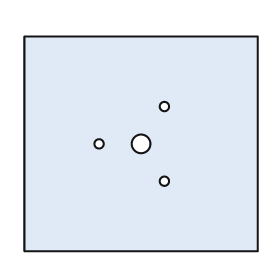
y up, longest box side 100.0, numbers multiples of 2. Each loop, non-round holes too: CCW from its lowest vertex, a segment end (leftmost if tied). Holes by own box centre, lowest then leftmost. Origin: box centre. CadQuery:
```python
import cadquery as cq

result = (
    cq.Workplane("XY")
    .moveTo(-50.0, -46.0)
    .lineTo(50.0, -46.0)
    .lineTo(50.0, 46.0)
    .lineTo(-50.0, 46.0)
    .close()
    .moveTo(10.0, -16.0)
    .circle(2.0)
    .moveTo(-18.0, 0.0)
    .circle(2.0)
    .moveTo(0.0, 0.0)
    .circle(4.0)
    .moveTo(10.0, 16.0)
    .circle(2.0)
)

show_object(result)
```